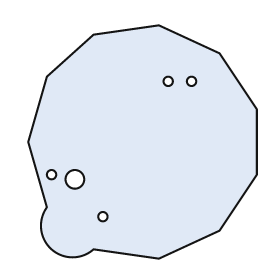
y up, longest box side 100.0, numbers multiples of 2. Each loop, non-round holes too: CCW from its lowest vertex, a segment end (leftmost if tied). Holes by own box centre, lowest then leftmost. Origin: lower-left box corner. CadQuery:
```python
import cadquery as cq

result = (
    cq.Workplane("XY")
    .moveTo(56.0, 0.0)
    .lineTo(82.0, 12.0)
    .lineTo(98.0, 36.0)
    .lineTo(98.0, 64.0)
    .lineTo(82.0, 88.0)
    .lineTo(56.0, 100.0)
    .lineTo(28.0, 96.0)
    .lineTo(8.0, 78.0)
    .lineTo(0.0, 50.0)
    .lineTo(8.0, 22.0)
    .threePointArc((10.0, 4.0), (28.0, 4.0))
    .close()
    .moveTo(32.0, 18.0)
    .circle(2.0)
    .moveTo(20.0, 34.0)
    .circle(4.0)
    .moveTo(10.0, 36.0)
    .circle(2.0)
    .moveTo(60.0, 76.0)
    .circle(2.0)
    .moveTo(70.0, 76.0)
    .circle(2.0)
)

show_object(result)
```